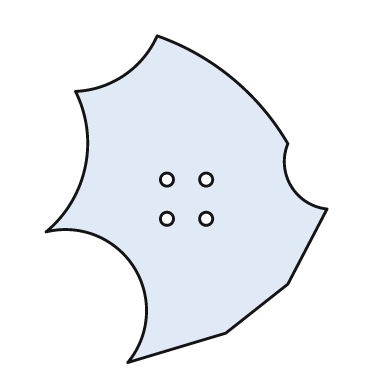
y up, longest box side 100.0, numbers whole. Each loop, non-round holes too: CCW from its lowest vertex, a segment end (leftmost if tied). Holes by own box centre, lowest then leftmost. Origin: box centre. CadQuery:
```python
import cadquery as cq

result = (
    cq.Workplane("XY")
    .moveTo(-18.0, -50.0)
    .lineTo(12.0, -41.0)
    .lineTo(31.0, -26.0)
    .lineTo(43.0, -3.0)
    .threePointArc((32.0, 4.0), (31.0, 17.0))
    .threePointArc((14.0, 37.0), (-9.0, 50.0))
    .threePointArc((-19.0, 38.0), (-34.0, 33.0))
    .threePointArc((-31.0, 10.0), (-43.0, -10.0))
    .threePointArc((-16.0, -21.0), (-18.0, -50.0))
    .close()
    .moveTo(-6.0, -6.0)
    .circle(2.0)
    .moveTo(6.0, -6.0)
    .circle(2.0)
    .moveTo(-6.0, 6.0)
    .circle(2.0)
    .moveTo(6.0, 6.0)
    .circle(2.0)
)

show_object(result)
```